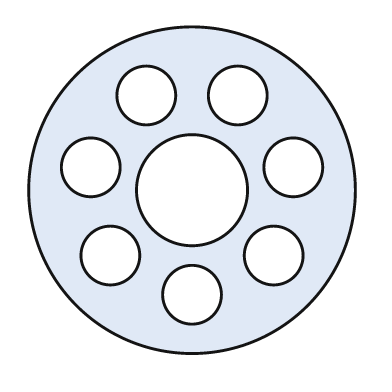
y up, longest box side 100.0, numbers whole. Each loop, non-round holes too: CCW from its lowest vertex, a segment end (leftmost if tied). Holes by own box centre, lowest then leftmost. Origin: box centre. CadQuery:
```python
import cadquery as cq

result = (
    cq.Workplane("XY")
    .moveTo(0.0, 0.0)
    .circle(50.0)
    .moveTo(0.0, -32.0)
    .circle(9.0)
    .moveTo(-25.0, -20.0)
    .circle(9.0)
    .moveTo(25.0, -20.0)
    .circle(9.0)
    .moveTo(0.0, 0.0)
    .circle(17.0)
    .moveTo(-31.0, 7.0)
    .circle(9.0)
    .moveTo(31.0, 7.0)
    .circle(9.0)
    .moveTo(-14.0, 29.0)
    .circle(9.0)
    .moveTo(14.0, 29.0)
    .circle(9.0)
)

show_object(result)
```